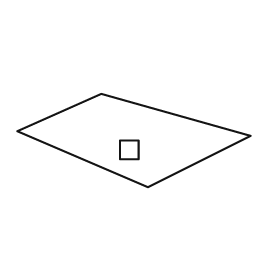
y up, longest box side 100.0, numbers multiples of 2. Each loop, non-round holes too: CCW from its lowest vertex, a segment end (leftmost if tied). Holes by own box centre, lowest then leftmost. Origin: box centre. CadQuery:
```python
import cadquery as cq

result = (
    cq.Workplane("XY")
    .moveTo(6.0, -20.0)
    .lineTo(50.0, 2.0)
    .lineTo(-14.0, 20.0)
    .lineTo(-50.0, 4.0)
    .close()
    .moveTo(-6.0, -8.0)
    .lineTo(2.0, -8.0)
    .lineTo(2.0, 0.0)
    .lineTo(-6.0, 0.0)
    .close()
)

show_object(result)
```